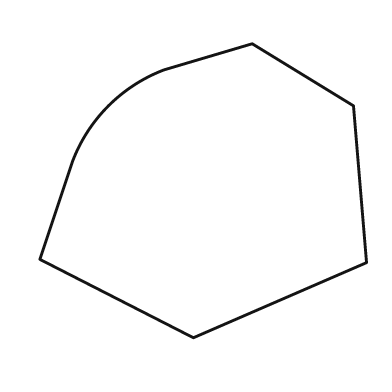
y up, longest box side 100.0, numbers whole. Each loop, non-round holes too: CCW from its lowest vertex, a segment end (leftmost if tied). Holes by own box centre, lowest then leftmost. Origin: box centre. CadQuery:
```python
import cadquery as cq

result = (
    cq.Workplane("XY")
    .moveTo(-3.0, -45.0)
    .lineTo(50.0, -22.0)
    .lineTo(46.0, 26.0)
    .lineTo(15.0, 45.0)
    .lineTo(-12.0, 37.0)
    .threePointArc((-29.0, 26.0), (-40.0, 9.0))
    .lineTo(-50.0, -21.0)
    .close()
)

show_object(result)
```